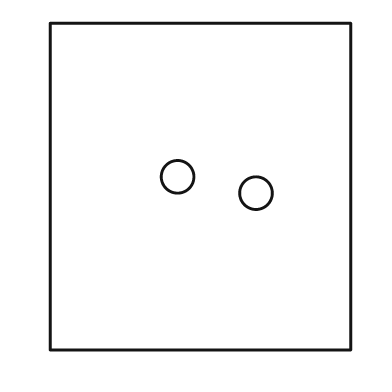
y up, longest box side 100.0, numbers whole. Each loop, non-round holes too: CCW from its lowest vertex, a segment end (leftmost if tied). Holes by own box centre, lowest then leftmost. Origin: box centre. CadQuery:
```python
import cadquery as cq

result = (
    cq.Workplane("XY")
    .moveTo(-46.0, -50.0)
    .lineTo(46.0, -50.0)
    .lineTo(46.0, 50.0)
    .lineTo(-46.0, 50.0)
    .close()
    .moveTo(17.0, -2.0)
    .circle(5.0)
    .moveTo(-7.0, 3.0)
    .circle(5.0)
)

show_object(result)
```